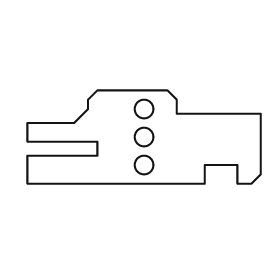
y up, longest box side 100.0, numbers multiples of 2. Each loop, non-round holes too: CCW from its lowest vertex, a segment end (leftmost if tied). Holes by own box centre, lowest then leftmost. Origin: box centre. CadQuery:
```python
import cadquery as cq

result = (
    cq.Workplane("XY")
    .moveTo(-50.0, -20.0)
    .lineTo(26.0, -20.0)
    .lineTo(26.0, -12.0)
    .lineTo(40.0, -12.0)
    .lineTo(40.0, -20.0)
    .lineTo(46.0, -20.0)
    .lineTo(50.0, -16.0)
    .lineTo(50.0, 10.0)
    .lineTo(14.0, 10.0)
    .lineTo(14.0, 16.0)
    .lineTo(10.0, 20.0)
    .lineTo(-20.0, 20.0)
    .lineTo(-24.0, 16.0)
    .lineTo(-24.0, 12.0)
    .lineTo(-30.0, 6.0)
    .lineTo(-50.0, 6.0)
    .lineTo(-50.0, -2.0)
    .lineTo(-20.0, -2.0)
    .lineTo(-20.0, -8.0)
    .lineTo(-50.0, -8.0)
    .close()
    .moveTo(0.0, -12.0)
    .circle(4.0)
    .moveTo(0.0, 0.0)
    .circle(4.0)
    .moveTo(0.0, 12.0)
    .circle(4.0)
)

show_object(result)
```